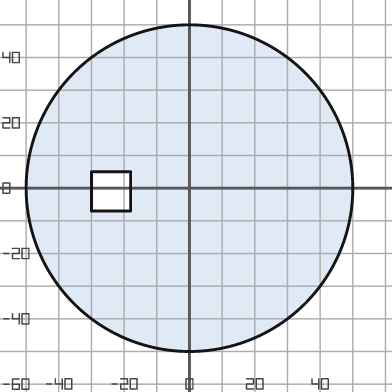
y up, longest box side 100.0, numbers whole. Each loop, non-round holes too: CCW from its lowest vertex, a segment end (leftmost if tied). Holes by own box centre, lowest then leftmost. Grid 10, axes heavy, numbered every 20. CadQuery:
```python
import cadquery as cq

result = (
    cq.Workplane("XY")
    .moveTo(0.0, 0.0)
    .circle(50.0)
    .moveTo(-30.0, -7.0)
    .lineTo(-18.0, -7.0)
    .lineTo(-18.0, 5.0)
    .lineTo(-30.0, 5.0)
    .close()
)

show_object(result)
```